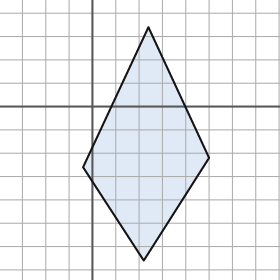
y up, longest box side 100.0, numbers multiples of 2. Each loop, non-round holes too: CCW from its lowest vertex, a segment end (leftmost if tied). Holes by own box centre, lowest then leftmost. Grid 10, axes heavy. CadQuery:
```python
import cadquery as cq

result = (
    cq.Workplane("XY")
    .moveTo(22.0, -66.0)
    .lineTo(50.0, -22.0)
    .lineTo(24.0, 34.0)
    .lineTo(-4.0, -26.0)
    .close()
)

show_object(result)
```